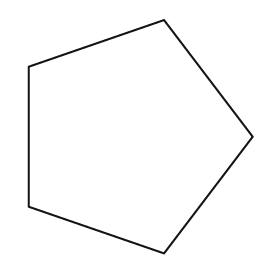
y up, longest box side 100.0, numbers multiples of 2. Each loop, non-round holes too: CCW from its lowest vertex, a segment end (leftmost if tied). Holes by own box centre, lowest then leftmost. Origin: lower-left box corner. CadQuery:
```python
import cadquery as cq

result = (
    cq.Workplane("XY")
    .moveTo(58.0, 0.0)
    .lineTo(96.0, 50.0)
    .lineTo(58.0, 100.0)
    .lineTo(0.0, 80.0)
    .lineTo(0.0, 20.0)
    .close()
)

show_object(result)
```